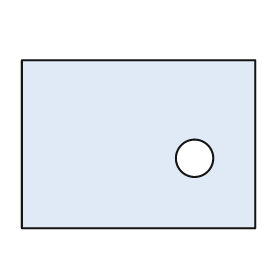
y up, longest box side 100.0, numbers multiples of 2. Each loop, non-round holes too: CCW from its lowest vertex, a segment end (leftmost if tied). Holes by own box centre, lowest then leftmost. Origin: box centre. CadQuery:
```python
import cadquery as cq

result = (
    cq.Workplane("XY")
    .moveTo(-50.0, -36.0)
    .lineTo(50.0, -36.0)
    .lineTo(50.0, 36.0)
    .lineTo(-50.0, 36.0)
    .close()
    .moveTo(24.0, -6.0)
    .circle(8.0)
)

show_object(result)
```